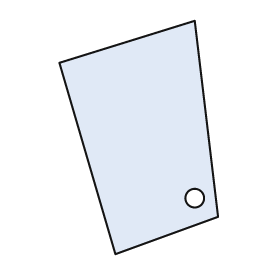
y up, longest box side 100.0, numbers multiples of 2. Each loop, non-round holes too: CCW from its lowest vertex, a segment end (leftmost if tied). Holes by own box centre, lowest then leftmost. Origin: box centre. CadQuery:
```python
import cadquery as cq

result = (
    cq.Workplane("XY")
    .moveTo(-10.0, -50.0)
    .lineTo(34.0, -34.0)
    .lineTo(24.0, 50.0)
    .lineTo(-34.0, 32.0)
    .close()
    .moveTo(24.0, -26.0)
    .circle(4.0)
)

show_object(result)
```